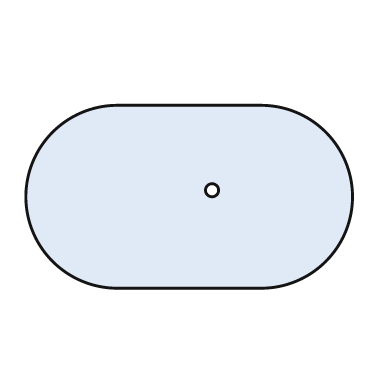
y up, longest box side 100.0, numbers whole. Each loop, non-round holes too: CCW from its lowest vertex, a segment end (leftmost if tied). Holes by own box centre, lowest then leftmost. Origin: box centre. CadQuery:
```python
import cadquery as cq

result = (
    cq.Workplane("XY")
    .moveTo(-22.0, -28.0)
    .lineTo(22.0, -28.0)
    .threePointArc((50.0, 0.0), (22.0, 28.0))
    .lineTo(-22.0, 28.0)
    .threePointArc((-50.0, 0.0), (-22.0, -28.0))
    .close()
    .moveTo(7.0, 2.0)
    .circle(2.0)
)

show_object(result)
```